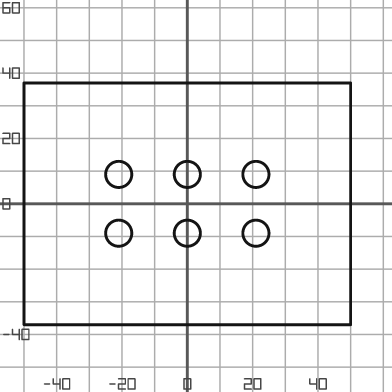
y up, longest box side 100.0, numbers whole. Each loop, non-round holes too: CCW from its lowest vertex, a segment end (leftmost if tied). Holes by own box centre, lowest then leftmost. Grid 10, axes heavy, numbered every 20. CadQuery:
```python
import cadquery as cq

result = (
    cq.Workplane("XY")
    .moveTo(-50.0, -37.0)
    .lineTo(50.0, -37.0)
    .lineTo(50.0, 37.0)
    .lineTo(-50.0, 37.0)
    .close()
    .moveTo(-21.0, -9.0)
    .circle(4.0)
    .moveTo(0.0, -9.0)
    .circle(4.0)
    .moveTo(21.0, -9.0)
    .circle(4.0)
    .moveTo(-21.0, 9.0)
    .circle(4.0)
    .moveTo(0.0, 9.0)
    .circle(4.0)
    .moveTo(21.0, 9.0)
    .circle(4.0)
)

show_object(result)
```